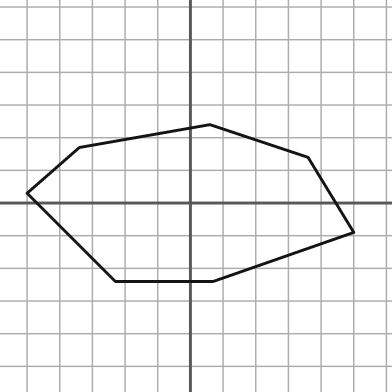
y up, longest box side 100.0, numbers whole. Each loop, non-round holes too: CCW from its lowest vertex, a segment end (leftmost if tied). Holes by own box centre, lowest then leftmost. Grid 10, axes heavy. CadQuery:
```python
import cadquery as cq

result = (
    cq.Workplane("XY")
    .moveTo(-23.0, -24.0)
    .lineTo(7.0, -24.0)
    .lineTo(50.0, -9.0)
    .lineTo(36.0, 14.0)
    .lineTo(6.0, 24.0)
    .lineTo(-34.0, 17.0)
    .lineTo(-50.0, 3.0)
    .close()
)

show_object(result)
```